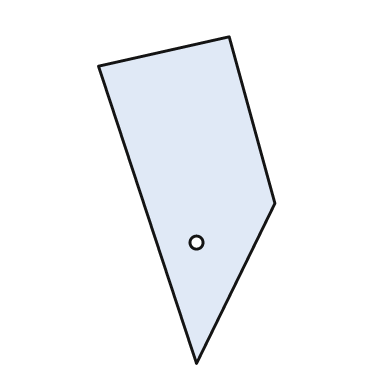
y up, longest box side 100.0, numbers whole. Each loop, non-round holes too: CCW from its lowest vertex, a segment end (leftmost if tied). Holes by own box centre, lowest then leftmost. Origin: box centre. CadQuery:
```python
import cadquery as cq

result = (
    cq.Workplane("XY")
    .moveTo(3.0, -50.0)
    .lineTo(27.0, -1.0)
    .lineTo(13.0, 50.0)
    .lineTo(-27.0, 41.0)
    .close()
    .moveTo(3.0, -13.0)
    .circle(2.0)
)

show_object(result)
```